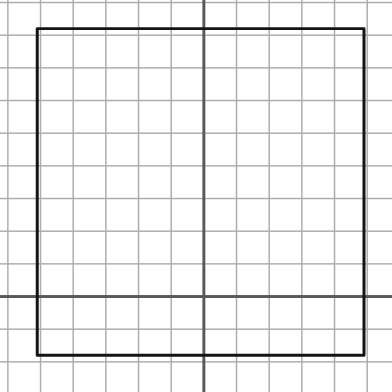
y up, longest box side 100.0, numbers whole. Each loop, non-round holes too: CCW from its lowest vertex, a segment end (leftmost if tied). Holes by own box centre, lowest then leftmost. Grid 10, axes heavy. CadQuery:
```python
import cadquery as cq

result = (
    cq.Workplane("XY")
    .moveTo(-51.0, -18.0)
    .lineTo(49.0, -18.0)
    .lineTo(49.0, 82.0)
    .lineTo(-51.0, 82.0)
    .close()
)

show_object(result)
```